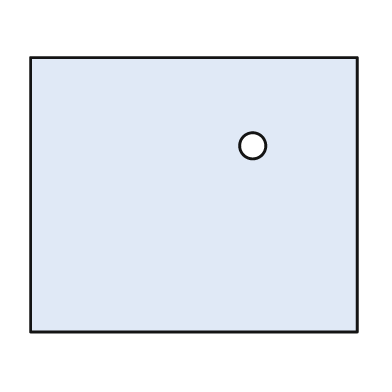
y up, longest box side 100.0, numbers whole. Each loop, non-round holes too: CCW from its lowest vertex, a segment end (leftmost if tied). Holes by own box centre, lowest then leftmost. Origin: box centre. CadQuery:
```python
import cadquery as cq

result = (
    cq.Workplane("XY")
    .moveTo(-50.0, -42.0)
    .lineTo(50.0, -42.0)
    .lineTo(50.0, 42.0)
    .lineTo(-50.0, 42.0)
    .close()
    .moveTo(18.0, 15.0)
    .circle(4.0)
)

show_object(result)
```